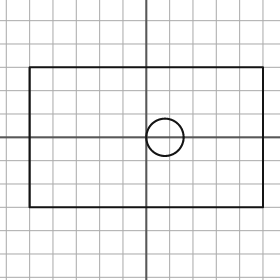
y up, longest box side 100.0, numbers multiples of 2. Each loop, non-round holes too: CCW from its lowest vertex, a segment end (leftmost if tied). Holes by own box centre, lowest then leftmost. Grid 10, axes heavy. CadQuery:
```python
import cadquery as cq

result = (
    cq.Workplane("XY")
    .moveTo(-50.0, -30.0)
    .lineTo(50.0, -30.0)
    .lineTo(50.0, 30.0)
    .lineTo(-50.0, 30.0)
    .close()
    .moveTo(8.0, 0.0)
    .circle(8.0)
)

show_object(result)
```